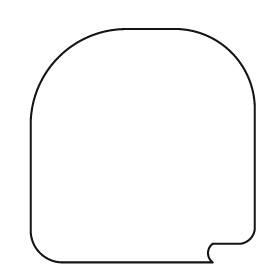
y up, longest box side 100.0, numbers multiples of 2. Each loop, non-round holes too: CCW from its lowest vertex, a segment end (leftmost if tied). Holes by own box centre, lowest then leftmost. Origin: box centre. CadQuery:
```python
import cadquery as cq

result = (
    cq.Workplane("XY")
    .moveTo(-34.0, -50.0)
    .lineTo(30.0, -50.0)
    .threePointArc((28.0, -46.0), (30.0, -42.0))
    .lineTo(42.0, -42.0)
    .threePointArc((46.0, -40.0), (48.0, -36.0))
    .lineTo(48.0, 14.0)
    .threePointArc((38.0, 40.0), (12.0, 50.0))
    .lineTo(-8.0, 50.0)
    .threePointArc((-36.0, 38.0), (-48.0, 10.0))
    .lineTo(-48.0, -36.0)
    .threePointArc((-44.0, -46.0), (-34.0, -50.0))
    .close()
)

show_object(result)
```